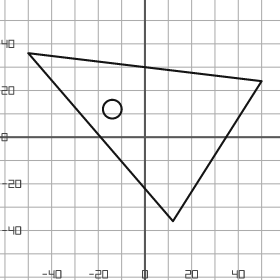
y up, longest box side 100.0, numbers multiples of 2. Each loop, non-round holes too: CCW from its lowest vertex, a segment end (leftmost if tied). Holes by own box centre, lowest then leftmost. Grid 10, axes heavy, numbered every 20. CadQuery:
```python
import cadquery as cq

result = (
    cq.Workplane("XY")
    .moveTo(12.0, -36.0)
    .lineTo(50.0, 24.0)
    .lineTo(-50.0, 36.0)
    .close()
    .moveTo(-14.0, 12.0)
    .circle(4.0)
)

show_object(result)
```